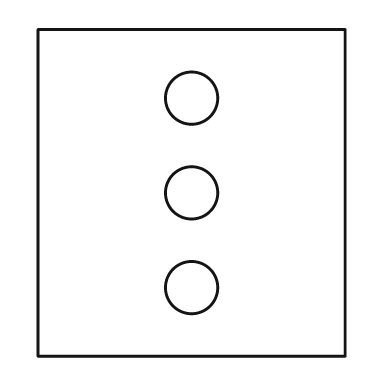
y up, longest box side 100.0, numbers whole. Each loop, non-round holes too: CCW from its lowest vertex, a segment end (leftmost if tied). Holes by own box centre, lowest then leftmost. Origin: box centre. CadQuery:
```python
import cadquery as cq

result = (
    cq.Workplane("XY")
    .moveTo(-47.0, -50.0)
    .lineTo(47.0, -50.0)
    .lineTo(47.0, 50.0)
    .lineTo(-47.0, 50.0)
    .close()
    .moveTo(0.0, -29.0)
    .circle(8.0)
    .moveTo(0.0, 0.0)
    .circle(8.0)
    .moveTo(0.0, 29.0)
    .circle(8.0)
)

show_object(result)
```